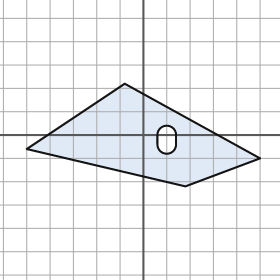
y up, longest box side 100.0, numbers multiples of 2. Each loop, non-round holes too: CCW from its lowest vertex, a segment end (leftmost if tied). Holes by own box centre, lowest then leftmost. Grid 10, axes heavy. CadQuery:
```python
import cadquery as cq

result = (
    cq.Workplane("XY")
    .moveTo(18.0, -22.0)
    .lineTo(50.0, -10.0)
    .lineTo(-8.0, 22.0)
    .lineTo(-50.0, -6.0)
    .close()
    .moveTo(6.0, -4.0)
    .threePointArc((10.0, -8.0), (14.0, -4.0))
    .lineTo(14.0, 0.0)
    .threePointArc((10.0, 4.0), (6.0, 0.0))
    .close()
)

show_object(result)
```